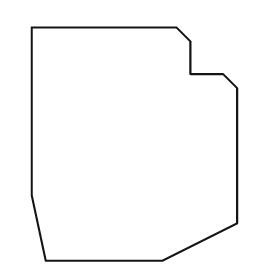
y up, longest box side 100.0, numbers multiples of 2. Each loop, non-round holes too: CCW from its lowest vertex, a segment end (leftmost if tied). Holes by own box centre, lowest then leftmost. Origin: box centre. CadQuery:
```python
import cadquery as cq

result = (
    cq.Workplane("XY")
    .moveTo(-38.0, -50.0)
    .lineTo(12.0, -50.0)
    .lineTo(44.0, -34.0)
    .lineTo(44.0, 24.0)
    .lineTo(38.0, 30.0)
    .lineTo(24.0, 30.0)
    .lineTo(24.0, 44.0)
    .lineTo(18.0, 50.0)
    .lineTo(-44.0, 50.0)
    .lineTo(-44.0, -22.0)
    .close()
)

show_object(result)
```